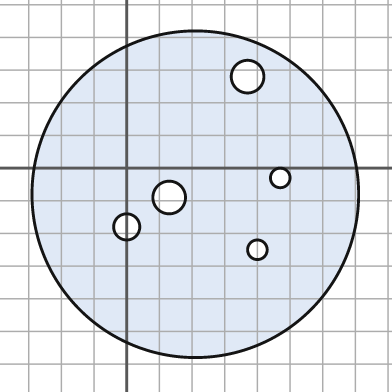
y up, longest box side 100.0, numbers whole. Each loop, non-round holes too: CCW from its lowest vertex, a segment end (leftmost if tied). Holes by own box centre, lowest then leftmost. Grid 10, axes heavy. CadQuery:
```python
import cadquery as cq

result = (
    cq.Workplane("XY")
    .moveTo(21.0, -8.0)
    .circle(50.0)
    .moveTo(40.0, -25.0)
    .circle(3.0)
    .moveTo(0.0, -18.0)
    .circle(4.0)
    .moveTo(13.0, -9.0)
    .circle(5.0)
    .moveTo(47.0, -3.0)
    .circle(3.0)
    .moveTo(37.0, 28.0)
    .circle(5.0)
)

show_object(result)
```